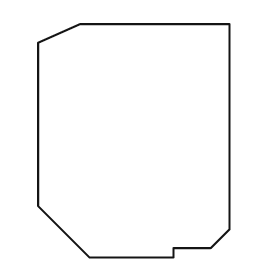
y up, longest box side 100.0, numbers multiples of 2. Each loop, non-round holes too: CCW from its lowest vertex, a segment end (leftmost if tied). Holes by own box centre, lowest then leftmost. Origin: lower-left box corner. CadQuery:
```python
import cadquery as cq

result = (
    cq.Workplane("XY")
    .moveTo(22.0, 0.0)
    .lineTo(58.0, 0.0)
    .lineTo(58.0, 4.0)
    .lineTo(74.0, 4.0)
    .lineTo(82.0, 12.0)
    .lineTo(82.0, 100.0)
    .lineTo(18.0, 100.0)
    .lineTo(0.0, 92.0)
    .lineTo(0.0, 22.0)
    .close()
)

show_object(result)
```